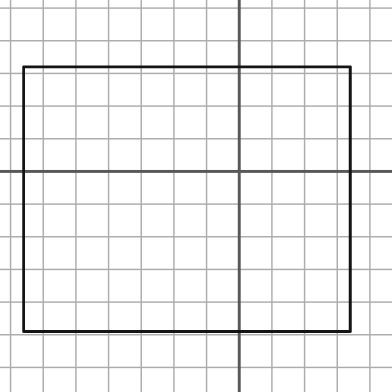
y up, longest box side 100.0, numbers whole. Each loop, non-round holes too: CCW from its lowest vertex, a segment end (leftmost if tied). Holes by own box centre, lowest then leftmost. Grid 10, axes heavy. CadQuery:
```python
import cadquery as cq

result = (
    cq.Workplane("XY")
    .moveTo(-66.0, -49.0)
    .lineTo(34.0, -49.0)
    .lineTo(34.0, 32.0)
    .lineTo(-66.0, 32.0)
    .close()
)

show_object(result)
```